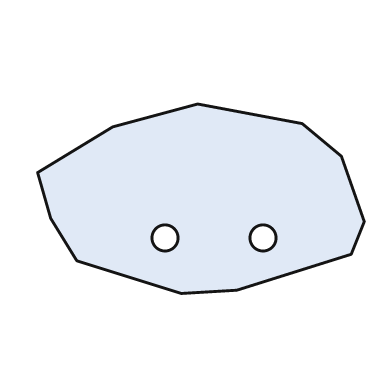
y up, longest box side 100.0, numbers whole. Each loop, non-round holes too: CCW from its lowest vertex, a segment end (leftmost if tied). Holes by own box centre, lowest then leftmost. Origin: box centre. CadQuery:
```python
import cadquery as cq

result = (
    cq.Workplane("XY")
    .moveTo(-6.0, -29.0)
    .lineTo(11.0, -28.0)
    .lineTo(46.0, -17.0)
    .lineTo(50.0, -7.0)
    .lineTo(43.0, 13.0)
    .lineTo(31.0, 23.0)
    .lineTo(-1.0, 29.0)
    .lineTo(-27.0, 22.0)
    .lineTo(-50.0, 8.0)
    .lineTo(-46.0, -6.0)
    .lineTo(-38.0, -19.0)
    .close()
    .moveTo(-11.0, -12.0)
    .circle(4.0)
    .moveTo(19.0, -12.0)
    .circle(4.0)
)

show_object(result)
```